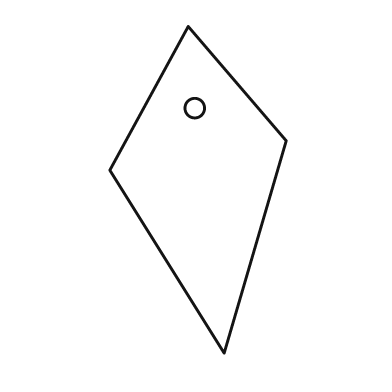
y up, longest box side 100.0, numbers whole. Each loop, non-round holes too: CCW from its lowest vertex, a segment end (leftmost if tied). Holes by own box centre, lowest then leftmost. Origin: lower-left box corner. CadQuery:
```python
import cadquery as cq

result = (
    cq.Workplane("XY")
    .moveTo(35.0, 0.0)
    .lineTo(54.0, 65.0)
    .lineTo(24.0, 100.0)
    .lineTo(0.0, 56.0)
    .close()
    .moveTo(26.0, 75.0)
    .circle(3.0)
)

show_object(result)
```